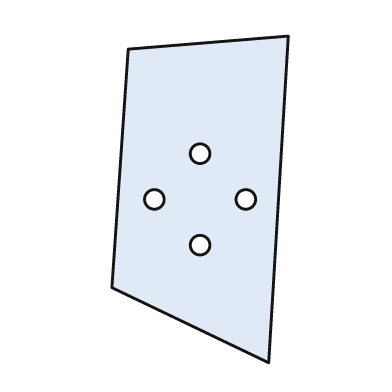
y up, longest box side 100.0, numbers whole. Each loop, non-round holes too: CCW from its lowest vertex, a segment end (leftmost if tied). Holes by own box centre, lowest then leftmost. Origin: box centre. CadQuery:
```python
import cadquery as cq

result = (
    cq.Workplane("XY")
    .moveTo(21.0, -50.0)
    .lineTo(27.0, 50.0)
    .lineTo(-22.0, 46.0)
    .lineTo(-27.0, -27.0)
    .close()
    .moveTo(0.0, -14.0)
    .circle(3.0)
    .moveTo(-14.0, 0.0)
    .circle(3.0)
    .moveTo(14.0, 0.0)
    .circle(3.0)
    .moveTo(0.0, 14.0)
    .circle(3.0)
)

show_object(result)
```